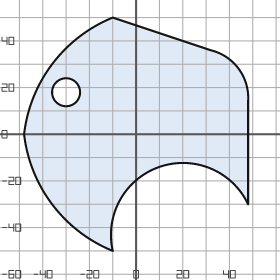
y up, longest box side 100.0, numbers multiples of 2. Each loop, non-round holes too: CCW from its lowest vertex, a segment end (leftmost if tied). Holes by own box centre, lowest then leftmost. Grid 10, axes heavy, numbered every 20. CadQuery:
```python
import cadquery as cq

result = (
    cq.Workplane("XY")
    .moveTo(-10.0, -50.0)
    .threePointArc((10.0, -14.0), (48.0, -30.0))
    .lineTo(48.0, 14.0)
    .threePointArc((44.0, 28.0), (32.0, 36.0))
    .lineTo(-10.0, 50.0)
    .threePointArc((-36.0, 30.0), (-48.0, 0.0))
    .threePointArc((-36.0, -30.0), (-10.0, -50.0))
    .close()
    .moveTo(-30.0, 18.0)
    .circle(6.0)
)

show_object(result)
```